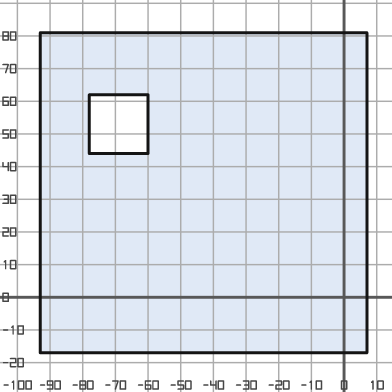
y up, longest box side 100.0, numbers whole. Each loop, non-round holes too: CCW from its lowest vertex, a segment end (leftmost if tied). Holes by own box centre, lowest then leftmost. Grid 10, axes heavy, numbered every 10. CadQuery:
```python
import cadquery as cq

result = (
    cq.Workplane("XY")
    .moveTo(-93.0, -17.0)
    .lineTo(7.0, -17.0)
    .lineTo(7.0, 81.0)
    .lineTo(-93.0, 81.0)
    .close()
    .moveTo(-78.0, 44.0)
    .lineTo(-60.0, 44.0)
    .lineTo(-60.0, 62.0)
    .lineTo(-78.0, 62.0)
    .close()
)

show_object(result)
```